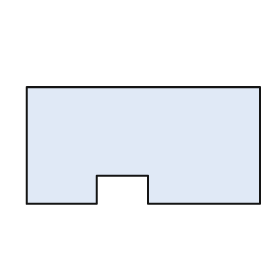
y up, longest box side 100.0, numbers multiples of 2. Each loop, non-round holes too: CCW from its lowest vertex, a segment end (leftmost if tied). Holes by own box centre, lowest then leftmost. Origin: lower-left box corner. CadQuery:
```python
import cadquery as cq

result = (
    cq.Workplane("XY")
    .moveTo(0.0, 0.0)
    .lineTo(30.0, 0.0)
    .lineTo(30.0, 12.0)
    .lineTo(52.0, 12.0)
    .lineTo(52.0, 0.0)
    .lineTo(100.0, 0.0)
    .lineTo(100.0, 50.0)
    .lineTo(0.0, 50.0)
    .close()
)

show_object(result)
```